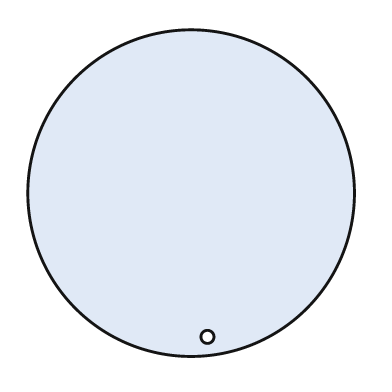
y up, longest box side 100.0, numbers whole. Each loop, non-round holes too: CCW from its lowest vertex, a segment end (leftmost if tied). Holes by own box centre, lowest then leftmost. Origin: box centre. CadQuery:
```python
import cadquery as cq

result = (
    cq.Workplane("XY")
    .moveTo(0.0, 0.0)
    .circle(50.0)
    .moveTo(5.0, -44.0)
    .circle(2.0)
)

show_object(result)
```